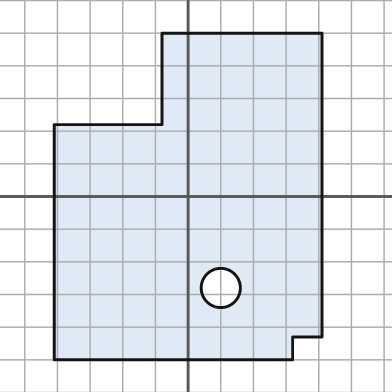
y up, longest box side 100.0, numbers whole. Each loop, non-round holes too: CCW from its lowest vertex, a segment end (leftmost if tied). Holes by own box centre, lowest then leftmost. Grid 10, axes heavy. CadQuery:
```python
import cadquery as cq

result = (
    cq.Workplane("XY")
    .moveTo(-41.0, -50.0)
    .lineTo(32.0, -50.0)
    .lineTo(32.0, -43.0)
    .lineTo(41.0, -43.0)
    .lineTo(41.0, 50.0)
    .lineTo(-8.0, 50.0)
    .lineTo(-8.0, 22.0)
    .lineTo(-41.0, 22.0)
    .close()
    .moveTo(10.0, -28.0)
    .circle(6.0)
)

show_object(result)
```